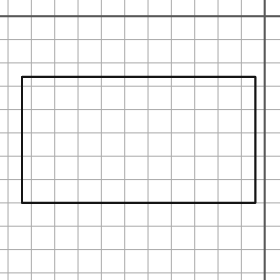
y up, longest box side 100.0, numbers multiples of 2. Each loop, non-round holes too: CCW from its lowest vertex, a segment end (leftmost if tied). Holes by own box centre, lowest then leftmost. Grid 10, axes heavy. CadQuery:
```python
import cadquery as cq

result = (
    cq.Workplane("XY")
    .moveTo(-104.0, -80.0)
    .lineTo(-4.0, -80.0)
    .lineTo(-4.0, -26.0)
    .lineTo(-104.0, -26.0)
    .close()
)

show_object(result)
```